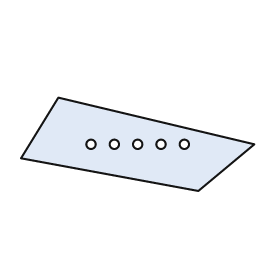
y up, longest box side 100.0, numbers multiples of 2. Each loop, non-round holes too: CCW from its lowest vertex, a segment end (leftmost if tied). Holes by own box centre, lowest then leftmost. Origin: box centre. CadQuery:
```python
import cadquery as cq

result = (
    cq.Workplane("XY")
    .moveTo(26.0, -20.0)
    .lineTo(50.0, 0.0)
    .lineTo(-34.0, 20.0)
    .lineTo(-50.0, -6.0)
    .close()
    .moveTo(-20.0, 0.0)
    .circle(2.0)
    .moveTo(-10.0, 0.0)
    .circle(2.0)
    .moveTo(0.0, 0.0)
    .circle(2.0)
    .moveTo(10.0, 0.0)
    .circle(2.0)
    .moveTo(20.0, 0.0)
    .circle(2.0)
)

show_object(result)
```